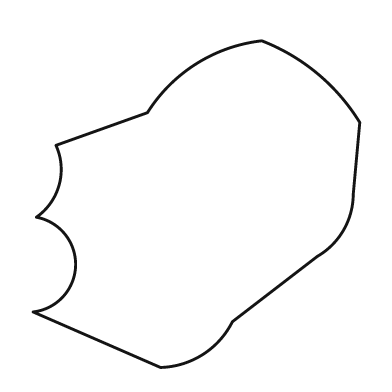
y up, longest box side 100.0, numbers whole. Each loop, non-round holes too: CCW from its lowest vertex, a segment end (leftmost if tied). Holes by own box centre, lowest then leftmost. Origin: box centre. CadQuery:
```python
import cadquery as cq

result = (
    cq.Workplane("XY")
    .moveTo(-11.0, -50.0)
    .threePointArc((2.0, -46.0), (11.0, -36.0))
    .lineTo(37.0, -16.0)
    .threePointArc((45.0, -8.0), (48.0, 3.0))
    .lineTo(50.0, 25.0)
    .threePointArc((37.0, 40.0), (20.0, 50.0))
    .threePointArc((0.0, 43.0), (-15.0, 28.0))
    .lineTo(-43.0, 18.0)
    .threePointArc((-42.0, 6.0), (-49.0, -4.0))
    .threePointArc((-37.0, -19.0), (-50.0, -33.0))
    .close()
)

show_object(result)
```